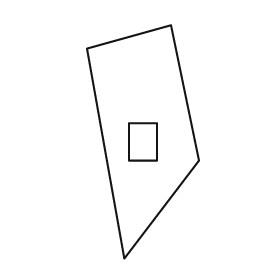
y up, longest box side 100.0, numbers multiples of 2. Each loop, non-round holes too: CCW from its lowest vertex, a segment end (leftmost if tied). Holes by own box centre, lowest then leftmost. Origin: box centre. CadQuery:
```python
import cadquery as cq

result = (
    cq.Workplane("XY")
    .moveTo(-8.0, -50.0)
    .lineTo(24.0, -8.0)
    .lineTo(12.0, 50.0)
    .lineTo(-24.0, 40.0)
    .close()
    .moveTo(-6.0, -8.0)
    .lineTo(6.0, -8.0)
    .lineTo(6.0, 8.0)
    .lineTo(-6.0, 8.0)
    .close()
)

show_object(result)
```